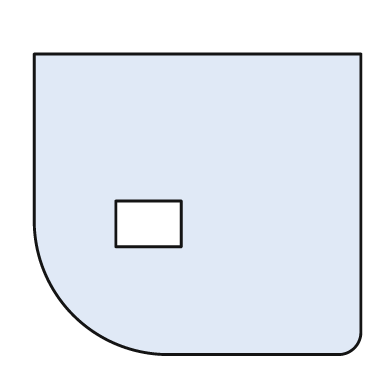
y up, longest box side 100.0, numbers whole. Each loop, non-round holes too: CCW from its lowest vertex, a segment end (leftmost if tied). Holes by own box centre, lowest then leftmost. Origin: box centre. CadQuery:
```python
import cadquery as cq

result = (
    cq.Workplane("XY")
    .moveTo(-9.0, -46.0)
    .lineTo(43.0, -46.0)
    .threePointArc((48.0, -44.0), (50.0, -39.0))
    .lineTo(50.0, 46.0)
    .lineTo(-50.0, 46.0)
    .lineTo(-50.0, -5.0)
    .threePointArc((-38.0, -34.0), (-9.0, -46.0))
    .close()
    .moveTo(-25.0, -13.0)
    .lineTo(-5.0, -13.0)
    .lineTo(-5.0, 1.0)
    .lineTo(-25.0, 1.0)
    .close()
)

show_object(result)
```